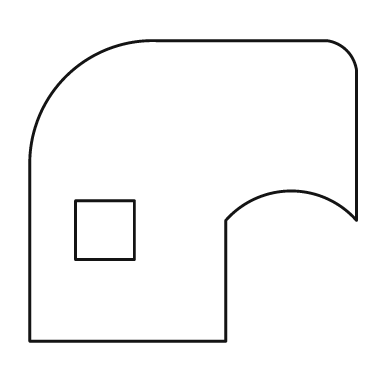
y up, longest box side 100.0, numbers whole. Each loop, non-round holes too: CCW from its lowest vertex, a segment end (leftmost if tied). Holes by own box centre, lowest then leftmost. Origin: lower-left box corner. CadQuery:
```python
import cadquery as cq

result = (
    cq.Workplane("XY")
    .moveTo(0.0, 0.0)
    .lineTo(60.0, 0.0)
    .lineTo(60.0, 37.0)
    .threePointArc((80.0, 46.0), (100.0, 37.0))
    .lineTo(100.0, 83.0)
    .threePointArc((97.0, 89.0), (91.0, 92.0))
    .lineTo(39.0, 92.0)
    .threePointArc((11.0, 81.0), (0.0, 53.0))
    .close()
    .moveTo(14.0, 25.0)
    .lineTo(32.0, 25.0)
    .lineTo(32.0, 43.0)
    .lineTo(14.0, 43.0)
    .close()
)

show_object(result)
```